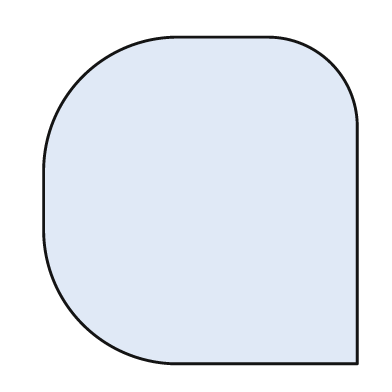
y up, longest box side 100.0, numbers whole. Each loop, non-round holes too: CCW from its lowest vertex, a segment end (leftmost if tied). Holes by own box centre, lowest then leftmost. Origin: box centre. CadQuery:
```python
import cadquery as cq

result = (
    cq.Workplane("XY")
    .moveTo(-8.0, -50.0)
    .lineTo(48.0, -50.0)
    .lineTo(48.0, 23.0)
    .threePointArc((40.0, 42.0), (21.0, 50.0))
    .lineTo(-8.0, 50.0)
    .threePointArc((-36.0, 38.0), (-48.0, 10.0))
    .lineTo(-48.0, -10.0)
    .threePointArc((-36.0, -38.0), (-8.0, -50.0))
    .close()
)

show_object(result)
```